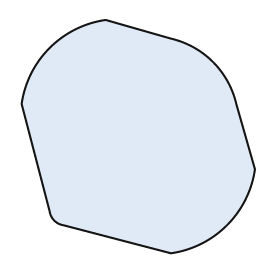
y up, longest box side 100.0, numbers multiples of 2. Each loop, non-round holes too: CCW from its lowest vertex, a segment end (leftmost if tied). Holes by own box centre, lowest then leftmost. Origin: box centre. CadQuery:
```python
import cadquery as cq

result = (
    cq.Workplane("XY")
    .moveTo(14.0, -50.0)
    .threePointArc((38.0, -38.0), (50.0, -14.0))
    .lineTo(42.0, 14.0)
    .threePointArc((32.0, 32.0), (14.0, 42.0))
    .lineTo(-14.0, 50.0)
    .threePointArc((-38.0, 38.0), (-50.0, 14.0))
    .lineTo(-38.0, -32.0)
    .threePointArc((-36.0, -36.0), (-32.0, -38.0))
    .close()
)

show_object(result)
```